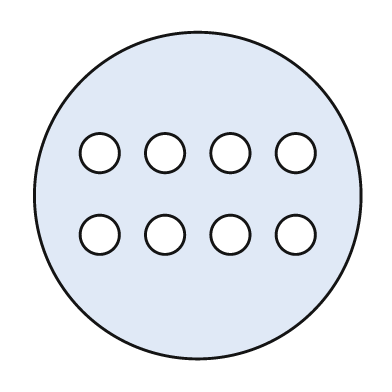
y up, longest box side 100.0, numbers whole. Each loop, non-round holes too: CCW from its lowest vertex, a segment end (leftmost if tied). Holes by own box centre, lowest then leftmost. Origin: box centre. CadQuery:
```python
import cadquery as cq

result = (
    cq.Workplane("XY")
    .moveTo(0.0, 0.0)
    .circle(50.0)
    .moveTo(-30.0, -12.0)
    .circle(6.0)
    .moveTo(-10.0, -12.0)
    .circle(6.0)
    .moveTo(10.0, -12.0)
    .circle(6.0)
    .moveTo(30.0, -12.0)
    .circle(6.0)
    .moveTo(-30.0, 13.0)
    .circle(6.0)
    .moveTo(-10.0, 13.0)
    .circle(6.0)
    .moveTo(10.0, 13.0)
    .circle(6.0)
    .moveTo(30.0, 13.0)
    .circle(6.0)
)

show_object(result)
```